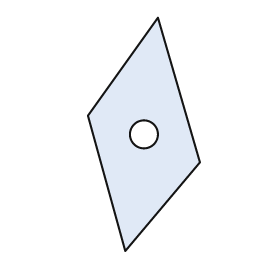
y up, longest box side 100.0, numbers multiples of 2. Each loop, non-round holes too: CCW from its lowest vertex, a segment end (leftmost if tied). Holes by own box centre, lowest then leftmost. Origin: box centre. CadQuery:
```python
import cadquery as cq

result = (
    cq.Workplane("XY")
    .moveTo(-8.0, -50.0)
    .lineTo(24.0, -12.0)
    .lineTo(6.0, 50.0)
    .lineTo(-24.0, 8.0)
    .close()
    .moveTo(0.0, 0.0)
    .circle(6.0)
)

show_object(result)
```